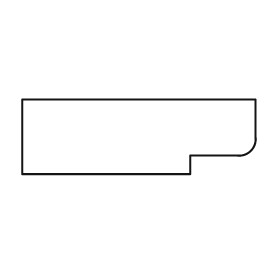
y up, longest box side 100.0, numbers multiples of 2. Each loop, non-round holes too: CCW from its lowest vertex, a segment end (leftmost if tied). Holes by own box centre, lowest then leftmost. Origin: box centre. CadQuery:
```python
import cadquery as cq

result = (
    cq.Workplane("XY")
    .moveTo(-50.0, -16.0)
    .lineTo(22.0, -16.0)
    .lineTo(22.0, -8.0)
    .lineTo(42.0, -8.0)
    .threePointArc((48.0, -6.0), (50.0, 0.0))
    .lineTo(50.0, 16.0)
    .lineTo(-50.0, 16.0)
    .close()
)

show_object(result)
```